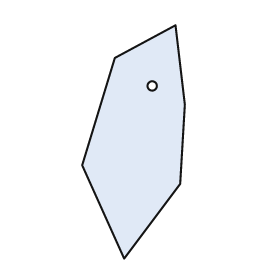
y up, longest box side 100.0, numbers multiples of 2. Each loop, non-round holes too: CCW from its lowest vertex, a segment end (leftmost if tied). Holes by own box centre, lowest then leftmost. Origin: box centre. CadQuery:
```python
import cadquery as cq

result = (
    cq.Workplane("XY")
    .moveTo(-4.0, -50.0)
    .lineTo(20.0, -18.0)
    .lineTo(22.0, 16.0)
    .lineTo(18.0, 50.0)
    .lineTo(-8.0, 36.0)
    .lineTo(-22.0, -10.0)
    .close()
    .moveTo(8.0, 24.0)
    .circle(2.0)
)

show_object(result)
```